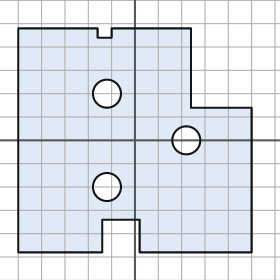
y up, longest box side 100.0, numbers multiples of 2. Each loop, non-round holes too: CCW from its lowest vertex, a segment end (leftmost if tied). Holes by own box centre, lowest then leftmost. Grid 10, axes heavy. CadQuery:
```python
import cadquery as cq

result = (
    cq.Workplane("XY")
    .moveTo(-50.0, -48.0)
    .lineTo(-14.0, -48.0)
    .lineTo(-14.0, -34.0)
    .lineTo(2.0, -34.0)
    .lineTo(2.0, -48.0)
    .lineTo(50.0, -48.0)
    .lineTo(50.0, 14.0)
    .lineTo(24.0, 14.0)
    .lineTo(24.0, 48.0)
    .lineTo(-10.0, 48.0)
    .lineTo(-10.0, 44.0)
    .lineTo(-16.0, 44.0)
    .lineTo(-16.0, 48.0)
    .lineTo(-50.0, 48.0)
    .close()
    .moveTo(-12.0, -20.0)
    .circle(6.0)
    .moveTo(22.0, 0.0)
    .circle(6.0)
    .moveTo(-12.0, 20.0)
    .circle(6.0)
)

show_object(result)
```